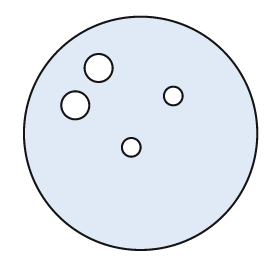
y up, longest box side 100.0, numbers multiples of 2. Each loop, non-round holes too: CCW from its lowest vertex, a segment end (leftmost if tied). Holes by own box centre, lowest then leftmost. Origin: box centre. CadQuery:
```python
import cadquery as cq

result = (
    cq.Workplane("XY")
    .moveTo(0.0, 0.0)
    .circle(50.0)
    .moveTo(-4.0, -6.0)
    .circle(4.0)
    .moveTo(-28.0, 12.0)
    .circle(6.0)
    .moveTo(14.0, 16.0)
    .circle(4.0)
    .moveTo(-18.0, 28.0)
    .circle(6.0)
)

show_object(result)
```